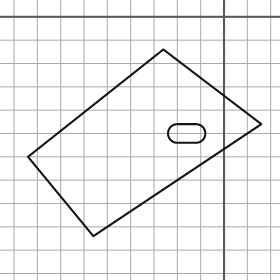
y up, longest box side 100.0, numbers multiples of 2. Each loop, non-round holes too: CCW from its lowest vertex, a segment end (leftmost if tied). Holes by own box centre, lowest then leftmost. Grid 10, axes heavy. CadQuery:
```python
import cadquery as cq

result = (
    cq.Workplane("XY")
    .moveTo(-56.0, -94.0)
    .lineTo(16.0, -46.0)
    .lineTo(-26.0, -14.0)
    .lineTo(-84.0, -60.0)
    .close()
    .moveTo(-20.0, -54.0)
    .lineTo(-12.0, -54.0)
    .threePointArc((-8.0, -50.0), (-12.0, -46.0))
    .lineTo(-20.0, -46.0)
    .threePointArc((-24.0, -50.0), (-20.0, -54.0))
    .close()
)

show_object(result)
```